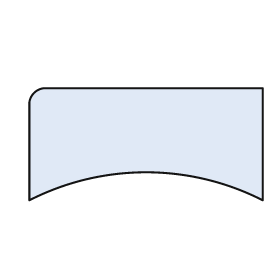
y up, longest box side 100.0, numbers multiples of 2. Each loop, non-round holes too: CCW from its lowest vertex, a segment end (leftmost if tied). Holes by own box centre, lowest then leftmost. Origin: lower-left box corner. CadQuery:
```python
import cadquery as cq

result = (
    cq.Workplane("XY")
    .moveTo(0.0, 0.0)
    .threePointArc((50.0, 12.0), (100.0, 0.0))
    .lineTo(100.0, 48.0)
    .lineTo(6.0, 48.0)
    .threePointArc((2.0, 46.0), (0.0, 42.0))
    .close()
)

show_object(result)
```